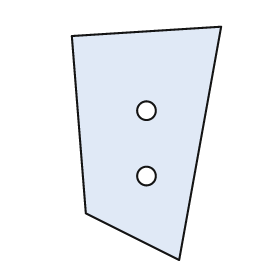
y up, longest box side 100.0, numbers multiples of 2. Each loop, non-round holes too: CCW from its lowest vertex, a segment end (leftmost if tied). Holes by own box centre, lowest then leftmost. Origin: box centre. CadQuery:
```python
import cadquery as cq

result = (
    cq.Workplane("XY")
    .moveTo(14.0, -50.0)
    .lineTo(32.0, 50.0)
    .lineTo(-32.0, 46.0)
    .lineTo(-26.0, -30.0)
    .close()
    .moveTo(0.0, -14.0)
    .circle(4.0)
    .moveTo(0.0, 14.0)
    .circle(4.0)
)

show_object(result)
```